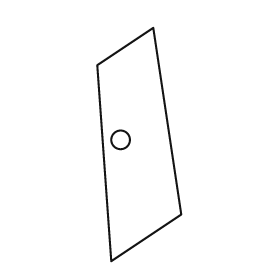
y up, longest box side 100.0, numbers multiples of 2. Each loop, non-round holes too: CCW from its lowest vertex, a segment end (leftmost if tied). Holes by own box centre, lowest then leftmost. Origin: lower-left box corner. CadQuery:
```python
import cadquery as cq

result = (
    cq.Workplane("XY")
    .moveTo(6.0, 0.0)
    .lineTo(36.0, 20.0)
    .lineTo(24.0, 100.0)
    .lineTo(0.0, 84.0)
    .close()
    .moveTo(10.0, 52.0)
    .circle(4.0)
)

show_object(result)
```